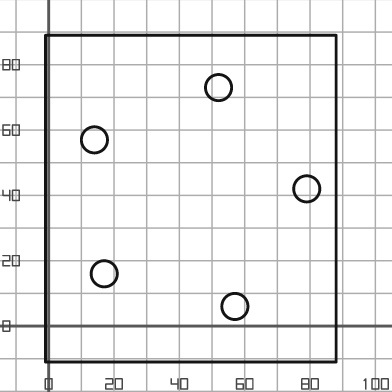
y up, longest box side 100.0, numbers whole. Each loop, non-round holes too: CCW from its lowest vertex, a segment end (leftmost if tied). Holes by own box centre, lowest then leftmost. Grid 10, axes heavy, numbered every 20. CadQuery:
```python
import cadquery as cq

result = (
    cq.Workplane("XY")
    .moveTo(-1.0, -11.0)
    .lineTo(88.0, -11.0)
    .lineTo(88.0, 89.0)
    .lineTo(-1.0, 89.0)
    .close()
    .moveTo(57.0, 6.0)
    .circle(4.0)
    .moveTo(17.0, 16.0)
    .circle(4.0)
    .moveTo(79.0, 42.0)
    .circle(4.0)
    .moveTo(14.0, 57.0)
    .circle(4.0)
    .moveTo(52.0, 73.0)
    .circle(4.0)
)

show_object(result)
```